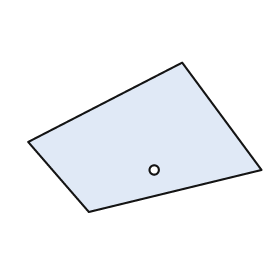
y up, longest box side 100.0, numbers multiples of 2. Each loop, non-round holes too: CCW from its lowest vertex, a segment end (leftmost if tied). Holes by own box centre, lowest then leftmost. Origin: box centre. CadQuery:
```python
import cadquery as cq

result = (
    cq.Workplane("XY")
    .moveTo(-24.0, -32.0)
    .lineTo(50.0, -14.0)
    .lineTo(16.0, 32.0)
    .lineTo(-50.0, -2.0)
    .close()
    .moveTo(4.0, -14.0)
    .circle(2.0)
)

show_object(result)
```